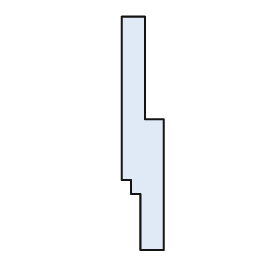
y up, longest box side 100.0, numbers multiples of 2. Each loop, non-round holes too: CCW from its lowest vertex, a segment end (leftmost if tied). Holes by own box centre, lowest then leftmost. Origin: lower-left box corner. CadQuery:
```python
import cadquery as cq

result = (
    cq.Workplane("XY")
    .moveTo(8.0, 0.0)
    .lineTo(18.0, 0.0)
    .lineTo(18.0, 56.0)
    .lineTo(10.0, 56.0)
    .lineTo(10.0, 100.0)
    .lineTo(0.0, 100.0)
    .lineTo(0.0, 30.0)
    .lineTo(4.0, 30.0)
    .lineTo(4.0, 24.0)
    .lineTo(8.0, 24.0)
    .close()
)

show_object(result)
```